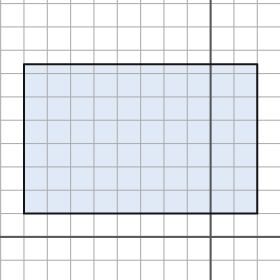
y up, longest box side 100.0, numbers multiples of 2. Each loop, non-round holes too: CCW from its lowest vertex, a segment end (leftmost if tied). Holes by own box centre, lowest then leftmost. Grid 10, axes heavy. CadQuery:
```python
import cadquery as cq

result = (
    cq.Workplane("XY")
    .moveTo(-80.0, 10.0)
    .lineTo(20.0, 10.0)
    .lineTo(20.0, 74.0)
    .lineTo(-80.0, 74.0)
    .close()
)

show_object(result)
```